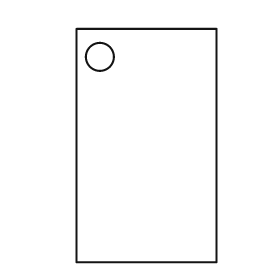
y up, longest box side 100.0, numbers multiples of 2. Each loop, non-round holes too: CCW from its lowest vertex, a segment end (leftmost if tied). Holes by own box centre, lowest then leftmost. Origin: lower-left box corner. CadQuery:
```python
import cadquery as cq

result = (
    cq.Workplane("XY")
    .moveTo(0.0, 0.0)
    .lineTo(60.0, 0.0)
    .lineTo(60.0, 100.0)
    .lineTo(0.0, 100.0)
    .close()
    .moveTo(10.0, 88.0)
    .circle(6.0)
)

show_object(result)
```